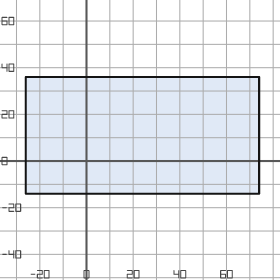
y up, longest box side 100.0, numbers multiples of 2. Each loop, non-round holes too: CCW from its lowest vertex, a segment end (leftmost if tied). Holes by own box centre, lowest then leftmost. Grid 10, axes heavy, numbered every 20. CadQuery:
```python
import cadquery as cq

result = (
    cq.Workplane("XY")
    .moveTo(-26.0, -14.0)
    .lineTo(74.0, -14.0)
    .lineTo(74.0, 36.0)
    .lineTo(-26.0, 36.0)
    .close()
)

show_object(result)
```